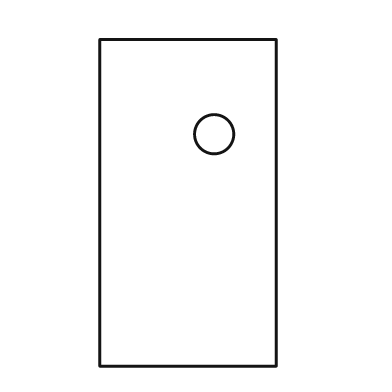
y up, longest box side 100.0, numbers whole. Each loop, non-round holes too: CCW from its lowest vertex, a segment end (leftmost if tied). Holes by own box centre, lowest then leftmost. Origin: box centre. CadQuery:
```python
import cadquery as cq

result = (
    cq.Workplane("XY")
    .moveTo(-27.0, -50.0)
    .lineTo(27.0, -50.0)
    .lineTo(27.0, 50.0)
    .lineTo(-27.0, 50.0)
    .close()
    .moveTo(8.0, 21.0)
    .circle(6.0)
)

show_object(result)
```